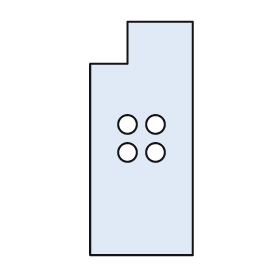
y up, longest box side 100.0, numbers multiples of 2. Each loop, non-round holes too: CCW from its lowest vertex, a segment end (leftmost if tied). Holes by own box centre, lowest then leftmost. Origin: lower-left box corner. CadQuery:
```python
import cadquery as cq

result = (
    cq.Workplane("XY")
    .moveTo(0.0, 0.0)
    .lineTo(44.0, 0.0)
    .lineTo(44.0, 100.0)
    .lineTo(16.0, 100.0)
    .lineTo(16.0, 82.0)
    .lineTo(0.0, 82.0)
    .close()
    .moveTo(16.0, 44.0)
    .circle(4.0)
    .moveTo(28.0, 44.0)
    .circle(4.0)
    .moveTo(16.0, 56.0)
    .circle(4.0)
    .moveTo(28.0, 56.0)
    .circle(4.0)
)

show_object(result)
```